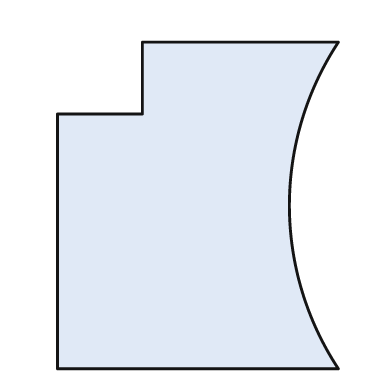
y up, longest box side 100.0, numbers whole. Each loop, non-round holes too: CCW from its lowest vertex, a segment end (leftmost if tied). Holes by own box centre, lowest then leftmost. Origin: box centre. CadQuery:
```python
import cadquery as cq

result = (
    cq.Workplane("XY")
    .moveTo(-43.0, -50.0)
    .lineTo(43.0, -50.0)
    .threePointArc((28.0, 0.0), (43.0, 50.0))
    .lineTo(-17.0, 50.0)
    .lineTo(-17.0, 28.0)
    .lineTo(-43.0, 28.0)
    .close()
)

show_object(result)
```